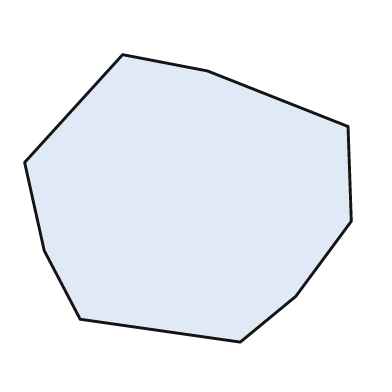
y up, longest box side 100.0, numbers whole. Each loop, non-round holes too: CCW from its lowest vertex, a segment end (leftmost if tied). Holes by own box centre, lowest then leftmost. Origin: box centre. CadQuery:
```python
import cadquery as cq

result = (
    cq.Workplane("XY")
    .moveTo(16.0, -44.0)
    .lineTo(33.0, -30.0)
    .lineTo(50.0, -7.0)
    .lineTo(49.0, 22.0)
    .lineTo(6.0, 39.0)
    .lineTo(-20.0, 44.0)
    .lineTo(-50.0, 11.0)
    .lineTo(-44.0, -16.0)
    .lineTo(-33.0, -37.0)
    .close()
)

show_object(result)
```